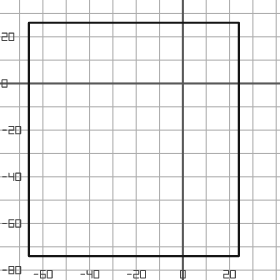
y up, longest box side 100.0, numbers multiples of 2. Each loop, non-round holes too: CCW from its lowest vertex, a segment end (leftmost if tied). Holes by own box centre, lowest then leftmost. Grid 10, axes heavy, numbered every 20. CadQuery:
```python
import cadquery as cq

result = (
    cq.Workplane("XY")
    .moveTo(-66.0, -74.0)
    .lineTo(24.0, -74.0)
    .lineTo(24.0, 26.0)
    .lineTo(-66.0, 26.0)
    .close()
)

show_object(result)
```